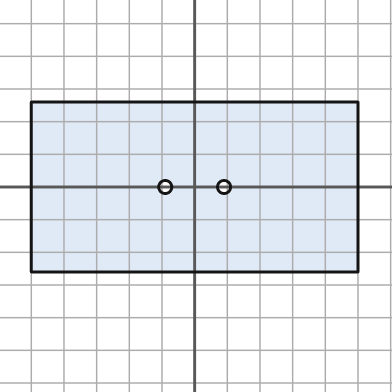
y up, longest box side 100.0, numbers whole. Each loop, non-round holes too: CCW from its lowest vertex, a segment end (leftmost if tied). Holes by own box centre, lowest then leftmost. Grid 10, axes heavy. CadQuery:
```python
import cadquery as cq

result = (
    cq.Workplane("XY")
    .moveTo(-50.0, -26.0)
    .lineTo(50.0, -26.0)
    .lineTo(50.0, 26.0)
    .lineTo(-50.0, 26.0)
    .close()
    .moveTo(-9.0, 0.0)
    .circle(2.0)
    .moveTo(9.0, 0.0)
    .circle(2.0)
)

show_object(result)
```